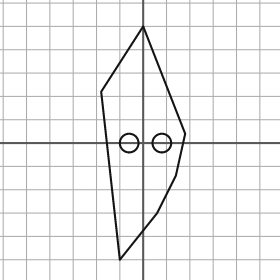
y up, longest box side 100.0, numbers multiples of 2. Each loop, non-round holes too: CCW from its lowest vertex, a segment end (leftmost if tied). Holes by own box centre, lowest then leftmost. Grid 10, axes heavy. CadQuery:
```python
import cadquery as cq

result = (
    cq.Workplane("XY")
    .moveTo(-10.0, -50.0)
    .lineTo(6.0, -30.0)
    .lineTo(14.0, -14.0)
    .lineTo(18.0, 4.0)
    .lineTo(0.0, 50.0)
    .lineTo(-18.0, 22.0)
    .close()
    .moveTo(-6.0, 0.0)
    .circle(4.0)
    .moveTo(8.0, 0.0)
    .circle(4.0)
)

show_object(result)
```